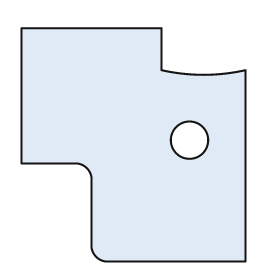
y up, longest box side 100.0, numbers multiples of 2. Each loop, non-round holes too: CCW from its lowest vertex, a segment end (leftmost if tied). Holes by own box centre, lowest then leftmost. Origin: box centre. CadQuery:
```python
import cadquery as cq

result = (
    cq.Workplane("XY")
    .moveTo(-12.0, -50.0)
    .lineTo(48.0, -50.0)
    .lineTo(48.0, 32.0)
    .threePointArc((30.0, 30.0), (12.0, 32.0))
    .lineTo(12.0, 50.0)
    .lineTo(-48.0, 50.0)
    .lineTo(-48.0, -8.0)
    .lineTo(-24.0, -8.0)
    .threePointArc((-20.0, -10.0), (-18.0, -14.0))
    .lineTo(-18.0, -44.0)
    .threePointArc((-16.0, -48.0), (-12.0, -50.0))
    .close()
    .moveTo(24.0, 2.0)
    .circle(8.0)
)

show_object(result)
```